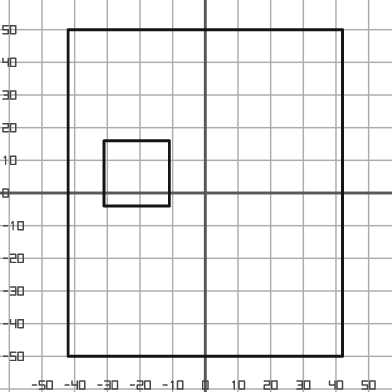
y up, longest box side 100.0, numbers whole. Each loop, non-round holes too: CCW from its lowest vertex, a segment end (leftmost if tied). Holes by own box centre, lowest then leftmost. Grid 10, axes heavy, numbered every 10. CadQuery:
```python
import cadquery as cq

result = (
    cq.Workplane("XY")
    .moveTo(-42.0, -50.0)
    .lineTo(42.0, -50.0)
    .lineTo(42.0, 50.0)
    .lineTo(-42.0, 50.0)
    .close()
    .moveTo(-31.0, -4.0)
    .lineTo(-11.0, -4.0)
    .lineTo(-11.0, 16.0)
    .lineTo(-31.0, 16.0)
    .close()
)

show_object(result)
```